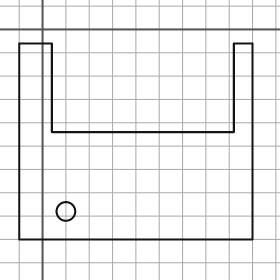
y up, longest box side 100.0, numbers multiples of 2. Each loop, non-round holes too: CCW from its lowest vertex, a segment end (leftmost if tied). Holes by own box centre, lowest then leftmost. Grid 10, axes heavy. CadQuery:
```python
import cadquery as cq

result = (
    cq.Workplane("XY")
    .moveTo(-10.0, -90.0)
    .lineTo(90.0, -90.0)
    .lineTo(90.0, -6.0)
    .lineTo(82.0, -6.0)
    .lineTo(82.0, -44.0)
    .lineTo(4.0, -44.0)
    .lineTo(4.0, -6.0)
    .lineTo(-10.0, -6.0)
    .close()
    .moveTo(10.0, -78.0)
    .circle(4.0)
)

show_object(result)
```